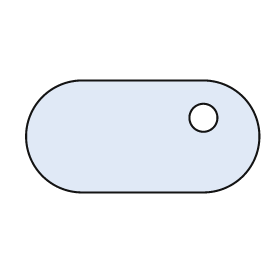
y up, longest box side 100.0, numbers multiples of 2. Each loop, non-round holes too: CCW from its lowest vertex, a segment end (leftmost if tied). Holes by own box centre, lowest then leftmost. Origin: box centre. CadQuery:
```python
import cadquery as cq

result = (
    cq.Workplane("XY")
    .moveTo(-26.0, -24.0)
    .lineTo(26.0, -24.0)
    .threePointArc((50.0, 0.0), (26.0, 24.0))
    .lineTo(-26.0, 24.0)
    .threePointArc((-50.0, 0.0), (-26.0, -24.0))
    .close()
    .moveTo(26.0, 8.0)
    .circle(6.0)
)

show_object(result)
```